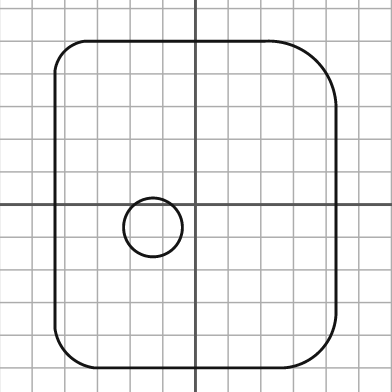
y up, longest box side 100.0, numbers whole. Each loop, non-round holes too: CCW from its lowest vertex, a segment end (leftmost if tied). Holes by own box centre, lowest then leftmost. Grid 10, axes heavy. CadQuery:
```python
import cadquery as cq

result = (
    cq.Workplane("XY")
    .moveTo(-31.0, -50.0)
    .lineTo(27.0, -50.0)
    .threePointArc((38.0, -45.0), (43.0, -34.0))
    .lineTo(43.0, 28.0)
    .threePointArc((37.0, 44.0), (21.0, 50.0))
    .lineTo(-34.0, 50.0)
    .threePointArc((-40.0, 47.0), (-43.0, 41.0))
    .lineTo(-43.0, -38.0)
    .threePointArc((-39.0, -46.0), (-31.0, -50.0))
    .close()
    .moveTo(-13.0, -7.0)
    .circle(9.0)
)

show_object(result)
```